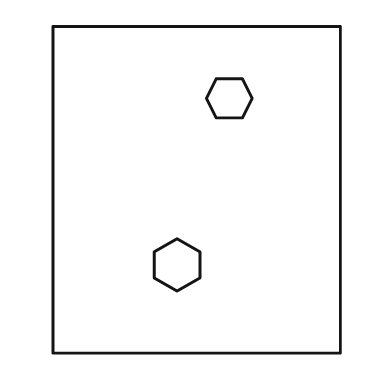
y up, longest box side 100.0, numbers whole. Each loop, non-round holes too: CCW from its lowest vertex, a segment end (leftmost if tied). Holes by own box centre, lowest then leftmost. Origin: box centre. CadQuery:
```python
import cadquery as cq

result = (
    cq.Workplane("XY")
    .moveTo(-44.0, -50.0)
    .lineTo(44.0, -50.0)
    .lineTo(44.0, 50.0)
    .lineTo(-44.0, 50.0)
    .close()
    .moveTo(-6.0, -31.0)
    .lineTo(1.0, -27.0)
    .lineTo(1.0, -19.0)
    .lineTo(-6.0, -15.0)
    .lineTo(-13.0, -19.0)
    .lineTo(-13.0, -27.0)
    .close()
    .moveTo(6.0, 22.0)
    .lineTo(14.0, 22.0)
    .lineTo(17.0, 28.0)
    .lineTo(14.0, 34.0)
    .lineTo(6.0, 34.0)
    .lineTo(3.0, 28.0)
    .close()
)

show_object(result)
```